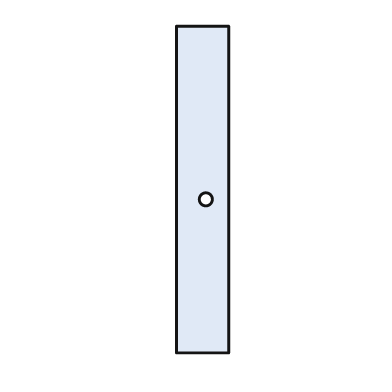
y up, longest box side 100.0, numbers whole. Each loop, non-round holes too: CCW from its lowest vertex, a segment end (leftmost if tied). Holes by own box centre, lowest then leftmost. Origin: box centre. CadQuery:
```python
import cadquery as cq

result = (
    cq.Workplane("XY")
    .moveTo(-8.0, -50.0)
    .lineTo(8.0, -50.0)
    .lineTo(8.0, 50.0)
    .lineTo(-8.0, 50.0)
    .close()
    .moveTo(1.0, -3.0)
    .circle(2.0)
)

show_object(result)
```